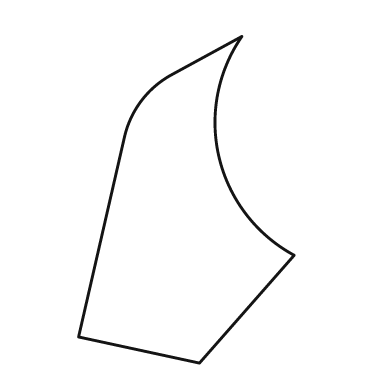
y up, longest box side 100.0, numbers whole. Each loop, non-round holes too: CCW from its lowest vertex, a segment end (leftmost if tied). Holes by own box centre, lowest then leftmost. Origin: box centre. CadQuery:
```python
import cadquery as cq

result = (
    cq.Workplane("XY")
    .moveTo(4.0, -50.0)
    .lineTo(33.0, -17.0)
    .threePointArc((10.0, 13.0), (17.0, 50.0))
    .lineTo(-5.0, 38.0)
    .threePointArc((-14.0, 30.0), (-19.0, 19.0))
    .lineTo(-33.0, -42.0)
    .close()
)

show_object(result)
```